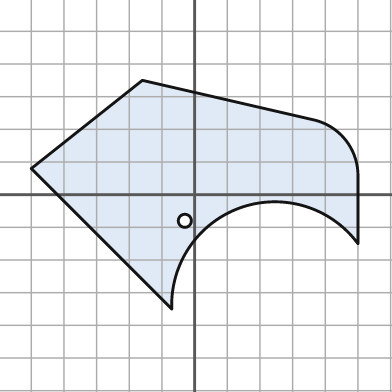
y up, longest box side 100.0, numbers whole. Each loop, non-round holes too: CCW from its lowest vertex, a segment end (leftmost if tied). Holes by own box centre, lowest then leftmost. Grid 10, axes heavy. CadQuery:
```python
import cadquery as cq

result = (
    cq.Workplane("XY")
    .moveTo(-7.0, -35.0)
    .threePointArc((14.0, -4.0), (50.0, -15.0))
    .lineTo(50.0, 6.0)
    .threePointArc((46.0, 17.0), (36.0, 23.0))
    .lineTo(-16.0, 35.0)
    .lineTo(-50.0, 8.0)
    .close()
    .moveTo(-3.0, -8.0)
    .circle(2.0)
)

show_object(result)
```